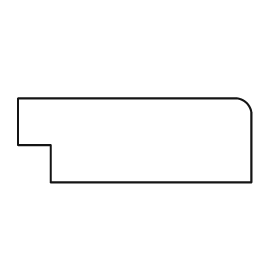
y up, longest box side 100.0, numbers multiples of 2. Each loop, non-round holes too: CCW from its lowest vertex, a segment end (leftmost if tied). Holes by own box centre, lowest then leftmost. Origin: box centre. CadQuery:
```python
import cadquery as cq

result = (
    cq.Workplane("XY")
    .moveTo(-36.0, -18.0)
    .lineTo(50.0, -18.0)
    .lineTo(50.0, 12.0)
    .threePointArc((48.0, 16.0), (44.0, 18.0))
    .lineTo(-50.0, 18.0)
    .lineTo(-50.0, -2.0)
    .lineTo(-36.0, -2.0)
    .close()
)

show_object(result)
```